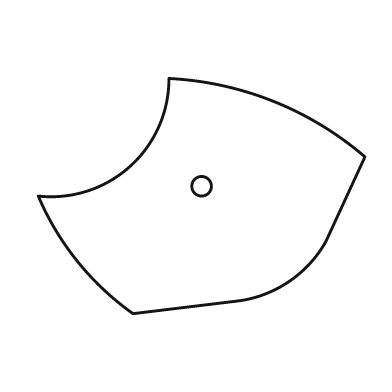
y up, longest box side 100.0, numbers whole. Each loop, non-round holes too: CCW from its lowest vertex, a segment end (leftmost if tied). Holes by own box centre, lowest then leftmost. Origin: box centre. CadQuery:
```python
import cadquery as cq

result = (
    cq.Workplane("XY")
    .moveTo(-21.0, -36.0)
    .lineTo(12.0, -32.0)
    .threePointArc((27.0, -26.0), (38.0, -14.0))
    .lineTo(50.0, 12.0)
    .threePointArc((22.0, 29.0), (-10.0, 36.0))
    .threePointArc((-22.0, 9.0), (-50.0, 0.0))
    .threePointArc((-38.0, -20.0), (-21.0, -36.0))
    .close()
    .moveTo(0.0, 3.0)
    .circle(3.0)
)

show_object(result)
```